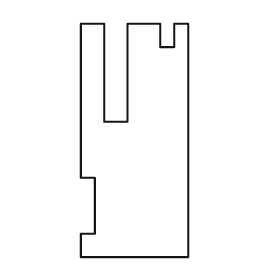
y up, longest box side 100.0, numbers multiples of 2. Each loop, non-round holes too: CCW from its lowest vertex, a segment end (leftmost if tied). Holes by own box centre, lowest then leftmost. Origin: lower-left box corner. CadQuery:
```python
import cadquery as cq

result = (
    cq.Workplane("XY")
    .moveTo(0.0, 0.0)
    .lineTo(46.0, 0.0)
    .lineTo(46.0, 100.0)
    .lineTo(40.0, 100.0)
    .lineTo(40.0, 90.0)
    .lineTo(34.0, 90.0)
    .lineTo(34.0, 100.0)
    .lineTo(20.0, 100.0)
    .lineTo(20.0, 58.0)
    .lineTo(10.0, 58.0)
    .lineTo(10.0, 100.0)
    .lineTo(0.0, 100.0)
    .lineTo(0.0, 34.0)
    .lineTo(6.0, 34.0)
    .lineTo(6.0, 10.0)
    .lineTo(0.0, 10.0)
    .close()
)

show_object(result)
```